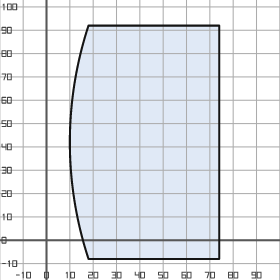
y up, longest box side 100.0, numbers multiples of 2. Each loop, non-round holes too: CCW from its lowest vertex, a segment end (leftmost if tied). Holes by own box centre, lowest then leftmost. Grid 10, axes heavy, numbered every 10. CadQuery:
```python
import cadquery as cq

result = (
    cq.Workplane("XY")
    .moveTo(18.0, -8.0)
    .lineTo(74.0, -8.0)
    .lineTo(74.0, 92.0)
    .lineTo(18.0, 92.0)
    .threePointArc((10.0, 42.0), (18.0, -8.0))
    .close()
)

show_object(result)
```